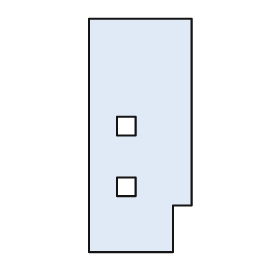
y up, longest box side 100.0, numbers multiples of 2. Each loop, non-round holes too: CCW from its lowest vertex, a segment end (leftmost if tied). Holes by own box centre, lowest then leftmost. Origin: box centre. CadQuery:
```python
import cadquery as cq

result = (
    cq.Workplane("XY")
    .moveTo(-22.0, -50.0)
    .lineTo(14.0, -50.0)
    .lineTo(14.0, -30.0)
    .lineTo(22.0, -30.0)
    .lineTo(22.0, 50.0)
    .lineTo(-22.0, 50.0)
    .close()
    .moveTo(-10.0, -26.0)
    .lineTo(-2.0, -26.0)
    .lineTo(-2.0, -18.0)
    .lineTo(-10.0, -18.0)
    .close()
    .moveTo(-10.0, 0.0)
    .lineTo(-2.0, 0.0)
    .lineTo(-2.0, 8.0)
    .lineTo(-10.0, 8.0)
    .close()
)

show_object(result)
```